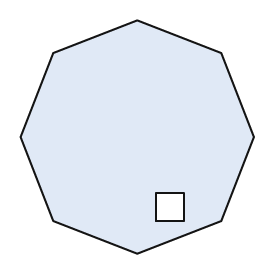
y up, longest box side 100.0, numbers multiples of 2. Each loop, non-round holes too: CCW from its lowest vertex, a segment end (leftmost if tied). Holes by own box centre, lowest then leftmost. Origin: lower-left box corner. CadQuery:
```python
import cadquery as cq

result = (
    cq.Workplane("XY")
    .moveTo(50.0, 0.0)
    .lineTo(86.0, 14.0)
    .lineTo(100.0, 50.0)
    .lineTo(86.0, 86.0)
    .lineTo(50.0, 100.0)
    .lineTo(14.0, 86.0)
    .lineTo(0.0, 50.0)
    .lineTo(14.0, 14.0)
    .close()
    .moveTo(58.0, 14.0)
    .lineTo(70.0, 14.0)
    .lineTo(70.0, 26.0)
    .lineTo(58.0, 26.0)
    .close()
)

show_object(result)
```